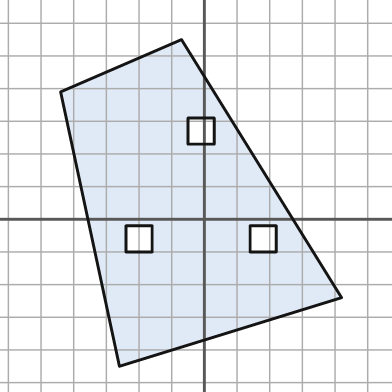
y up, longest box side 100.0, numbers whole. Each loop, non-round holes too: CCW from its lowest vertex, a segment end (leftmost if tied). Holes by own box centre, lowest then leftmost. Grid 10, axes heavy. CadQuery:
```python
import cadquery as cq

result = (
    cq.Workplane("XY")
    .moveTo(-26.0, -45.0)
    .lineTo(42.0, -24.0)
    .lineTo(-7.0, 55.0)
    .lineTo(-44.0, 39.0)
    .close()
    .moveTo(-24.0, -10.0)
    .lineTo(-16.0, -10.0)
    .lineTo(-16.0, -2.0)
    .lineTo(-24.0, -2.0)
    .close()
    .moveTo(14.0, -10.0)
    .lineTo(22.0, -10.0)
    .lineTo(22.0, -2.0)
    .lineTo(14.0, -2.0)
    .close()
    .moveTo(-5.0, 23.0)
    .lineTo(3.0, 23.0)
    .lineTo(3.0, 31.0)
    .lineTo(-5.0, 31.0)
    .close()
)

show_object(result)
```